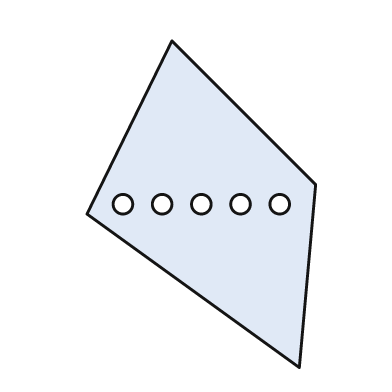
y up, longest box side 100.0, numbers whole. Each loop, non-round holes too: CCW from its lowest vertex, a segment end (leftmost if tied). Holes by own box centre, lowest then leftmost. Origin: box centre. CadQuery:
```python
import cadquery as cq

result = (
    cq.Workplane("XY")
    .moveTo(30.0, -50.0)
    .lineTo(35.0, 6.0)
    .lineTo(-9.0, 50.0)
    .lineTo(-35.0, -3.0)
    .close()
    .moveTo(-24.0, 0.0)
    .circle(3.0)
    .moveTo(-12.0, 0.0)
    .circle(3.0)
    .moveTo(0.0, 0.0)
    .circle(3.0)
    .moveTo(12.0, 0.0)
    .circle(3.0)
    .moveTo(24.0, 0.0)
    .circle(3.0)
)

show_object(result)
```